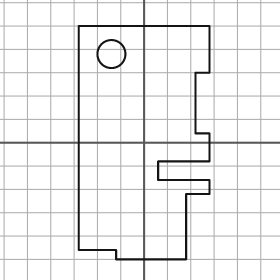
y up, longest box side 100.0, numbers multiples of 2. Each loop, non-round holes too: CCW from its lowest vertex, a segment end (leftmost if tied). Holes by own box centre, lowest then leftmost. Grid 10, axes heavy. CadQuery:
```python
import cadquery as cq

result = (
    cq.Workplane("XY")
    .moveTo(-12.0, -50.0)
    .lineTo(18.0, -50.0)
    .lineTo(18.0, -22.0)
    .lineTo(28.0, -22.0)
    .lineTo(28.0, -16.0)
    .lineTo(6.0, -16.0)
    .lineTo(6.0, -8.0)
    .lineTo(28.0, -8.0)
    .lineTo(28.0, 4.0)
    .lineTo(22.0, 4.0)
    .lineTo(22.0, 30.0)
    .lineTo(28.0, 30.0)
    .lineTo(28.0, 50.0)
    .lineTo(-28.0, 50.0)
    .lineTo(-28.0, -46.0)
    .lineTo(-12.0, -46.0)
    .close()
    .moveTo(-14.0, 38.0)
    .circle(6.0)
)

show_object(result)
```